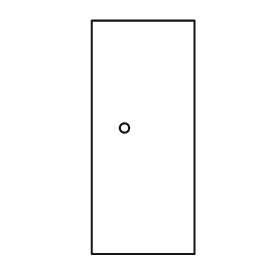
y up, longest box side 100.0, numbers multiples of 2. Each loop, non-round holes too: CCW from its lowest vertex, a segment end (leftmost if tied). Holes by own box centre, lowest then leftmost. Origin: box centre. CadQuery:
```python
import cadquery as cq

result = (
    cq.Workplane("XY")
    .moveTo(-22.0, -50.0)
    .lineTo(22.0, -50.0)
    .lineTo(22.0, 50.0)
    .lineTo(-22.0, 50.0)
    .close()
    .moveTo(-8.0, 4.0)
    .circle(2.0)
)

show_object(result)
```